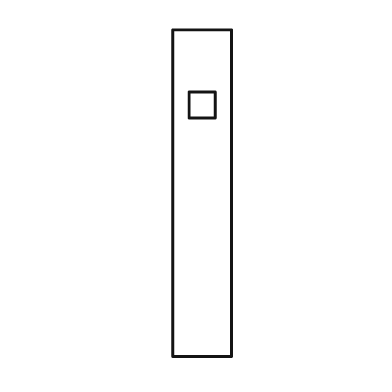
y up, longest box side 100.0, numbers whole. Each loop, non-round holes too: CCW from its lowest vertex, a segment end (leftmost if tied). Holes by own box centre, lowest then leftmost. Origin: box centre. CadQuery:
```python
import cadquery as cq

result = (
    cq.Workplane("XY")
    .moveTo(-9.0, -50.0)
    .lineTo(9.0, -50.0)
    .lineTo(9.0, 50.0)
    .lineTo(-9.0, 50.0)
    .close()
    .moveTo(-4.0, 23.0)
    .lineTo(4.0, 23.0)
    .lineTo(4.0, 31.0)
    .lineTo(-4.0, 31.0)
    .close()
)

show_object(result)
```